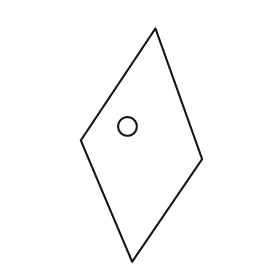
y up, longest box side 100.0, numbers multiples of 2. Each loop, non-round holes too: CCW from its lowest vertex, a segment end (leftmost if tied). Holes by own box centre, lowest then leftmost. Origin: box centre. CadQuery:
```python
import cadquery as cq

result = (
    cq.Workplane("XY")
    .moveTo(-4.0, -50.0)
    .lineTo(26.0, -6.0)
    .lineTo(6.0, 50.0)
    .lineTo(-26.0, 2.0)
    .close()
    .moveTo(-6.0, 8.0)
    .circle(4.0)
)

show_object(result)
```